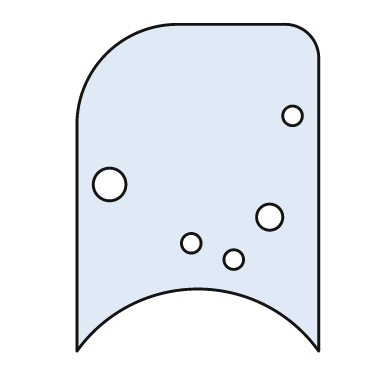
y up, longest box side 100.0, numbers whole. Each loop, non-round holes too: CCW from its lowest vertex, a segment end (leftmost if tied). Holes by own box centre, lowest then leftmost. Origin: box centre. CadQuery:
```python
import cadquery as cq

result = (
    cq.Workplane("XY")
    .moveTo(-37.0, -50.0)
    .threePointArc((0.0, -31.0), (37.0, -50.0))
    .lineTo(37.0, 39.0)
    .threePointArc((34.0, 47.0), (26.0, 50.0))
    .lineTo(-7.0, 50.0)
    .threePointArc((-28.0, 41.0), (-37.0, 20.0))
    .close()
    .moveTo(11.0, -22.0)
    .circle(3.0)
    .moveTo(-2.0, -17.0)
    .circle(3.0)
    .moveTo(22.0, -9.0)
    .circle(4.0)
    .moveTo(-27.0, 1.0)
    .circle(5.0)
    .moveTo(29.0, 22.0)
    .circle(3.0)
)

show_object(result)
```